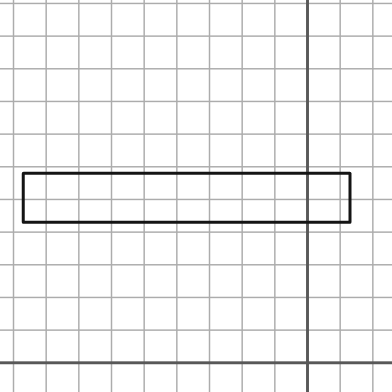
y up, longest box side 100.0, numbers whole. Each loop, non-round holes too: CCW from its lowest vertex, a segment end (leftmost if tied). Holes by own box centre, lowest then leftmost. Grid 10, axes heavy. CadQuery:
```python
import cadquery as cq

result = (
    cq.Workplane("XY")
    .moveTo(-87.0, 43.0)
    .lineTo(13.0, 43.0)
    .lineTo(13.0, 58.0)
    .lineTo(-87.0, 58.0)
    .close()
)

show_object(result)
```